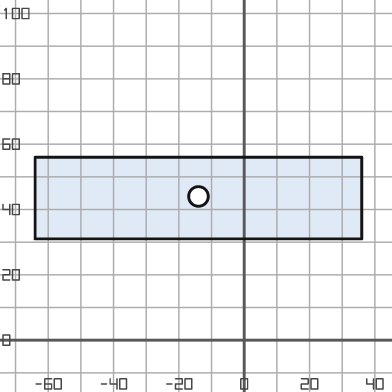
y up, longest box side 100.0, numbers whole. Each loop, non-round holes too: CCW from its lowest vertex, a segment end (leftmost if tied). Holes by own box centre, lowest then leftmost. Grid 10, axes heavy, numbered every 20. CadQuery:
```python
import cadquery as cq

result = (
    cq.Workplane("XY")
    .moveTo(-64.0, 31.0)
    .lineTo(36.0, 31.0)
    .lineTo(36.0, 56.0)
    .lineTo(-64.0, 56.0)
    .close()
    .moveTo(-14.0, 44.0)
    .circle(3.0)
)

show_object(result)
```